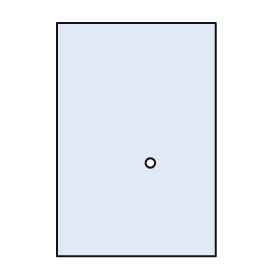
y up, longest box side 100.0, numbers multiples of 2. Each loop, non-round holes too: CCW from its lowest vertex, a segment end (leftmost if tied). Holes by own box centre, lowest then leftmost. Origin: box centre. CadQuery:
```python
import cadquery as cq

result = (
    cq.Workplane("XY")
    .moveTo(-34.0, -50.0)
    .lineTo(34.0, -50.0)
    .lineTo(34.0, 50.0)
    .lineTo(-34.0, 50.0)
    .close()
    .moveTo(6.0, -10.0)
    .circle(2.0)
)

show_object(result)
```